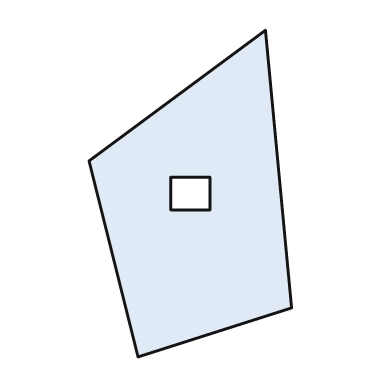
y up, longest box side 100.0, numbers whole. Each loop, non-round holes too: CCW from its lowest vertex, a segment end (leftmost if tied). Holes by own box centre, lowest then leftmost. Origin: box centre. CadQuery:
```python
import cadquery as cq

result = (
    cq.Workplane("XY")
    .moveTo(-16.0, -50.0)
    .lineTo(31.0, -35.0)
    .lineTo(23.0, 50.0)
    .lineTo(-31.0, 10.0)
    .close()
    .moveTo(-6.0, -5.0)
    .lineTo(6.0, -5.0)
    .lineTo(6.0, 5.0)
    .lineTo(-6.0, 5.0)
    .close()
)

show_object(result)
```